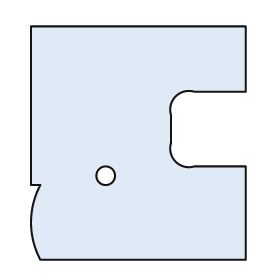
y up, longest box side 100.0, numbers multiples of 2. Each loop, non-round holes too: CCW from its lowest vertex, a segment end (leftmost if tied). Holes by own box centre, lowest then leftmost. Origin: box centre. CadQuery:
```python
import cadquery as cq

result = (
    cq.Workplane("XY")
    .moveTo(-42.0, -50.0)
    .lineTo(46.0, -50.0)
    .lineTo(46.0, -10.0)
    .lineTo(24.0, -10.0)
    .threePointArc((16.0, -8.0), (14.0, 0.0))
    .lineTo(14.0, 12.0)
    .threePointArc((16.0, 20.0), (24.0, 22.0))
    .lineTo(46.0, 22.0)
    .lineTo(46.0, 50.0)
    .lineTo(-46.0, 50.0)
    .lineTo(-46.0, -18.0)
    .lineTo(-42.0, -18.0)
    .threePointArc((-46.0, -34.0), (-42.0, -50.0))
    .close()
    .moveTo(-14.0, -14.0)
    .circle(4.0)
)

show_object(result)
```